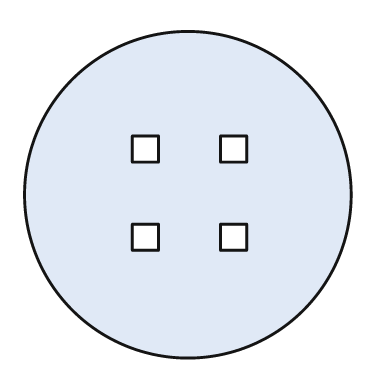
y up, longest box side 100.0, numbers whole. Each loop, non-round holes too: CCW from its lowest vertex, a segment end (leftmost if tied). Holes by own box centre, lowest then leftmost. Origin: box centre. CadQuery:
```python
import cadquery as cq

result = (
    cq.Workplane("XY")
    .moveTo(0.0, 0.0)
    .circle(50.0)
    .moveTo(-17.0, -17.0)
    .lineTo(-9.0, -17.0)
    .lineTo(-9.0, -9.0)
    .lineTo(-17.0, -9.0)
    .close()
    .moveTo(10.0, -17.0)
    .lineTo(18.0, -17.0)
    .lineTo(18.0, -9.0)
    .lineTo(10.0, -9.0)
    .close()
    .moveTo(-17.0, 10.0)
    .lineTo(-9.0, 10.0)
    .lineTo(-9.0, 18.0)
    .lineTo(-17.0, 18.0)
    .close()
    .moveTo(10.0, 10.0)
    .lineTo(18.0, 10.0)
    .lineTo(18.0, 18.0)
    .lineTo(10.0, 18.0)
    .close()
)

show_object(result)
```